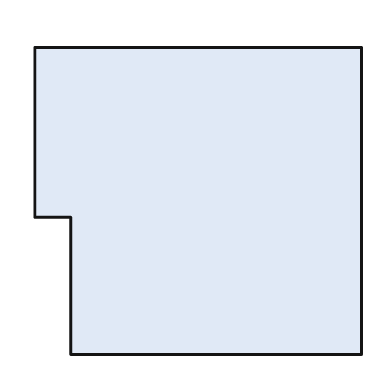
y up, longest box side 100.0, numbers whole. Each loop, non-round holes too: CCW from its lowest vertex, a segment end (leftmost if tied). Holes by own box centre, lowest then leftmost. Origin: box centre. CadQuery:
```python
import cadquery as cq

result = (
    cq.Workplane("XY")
    .moveTo(-39.0, -47.0)
    .lineTo(50.0, -47.0)
    .lineTo(50.0, 47.0)
    .lineTo(-50.0, 47.0)
    .lineTo(-50.0, -5.0)
    .lineTo(-39.0, -5.0)
    .close()
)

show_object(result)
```